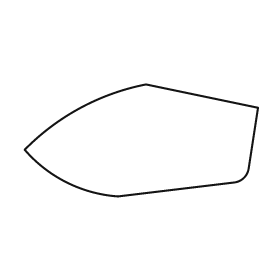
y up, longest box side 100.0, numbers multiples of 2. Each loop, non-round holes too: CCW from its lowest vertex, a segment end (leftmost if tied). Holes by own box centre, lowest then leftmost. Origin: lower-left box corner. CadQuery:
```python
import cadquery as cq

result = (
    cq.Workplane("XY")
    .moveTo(40.0, 0.0)
    .lineTo(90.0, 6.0)
    .threePointArc((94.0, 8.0), (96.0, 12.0))
    .lineTo(100.0, 38.0)
    .lineTo(52.0, 48.0)
    .threePointArc((24.0, 38.0), (0.0, 20.0))
    .threePointArc((18.0, 6.0), (40.0, 0.0))
    .close()
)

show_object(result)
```